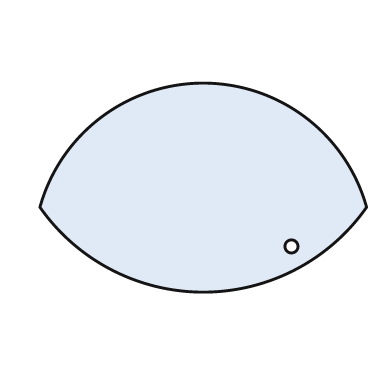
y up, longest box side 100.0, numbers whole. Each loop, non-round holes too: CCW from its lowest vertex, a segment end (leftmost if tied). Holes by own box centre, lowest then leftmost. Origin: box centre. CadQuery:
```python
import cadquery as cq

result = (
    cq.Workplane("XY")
    .moveTo(-50.0, -6.0)
    .threePointArc((0.0, -32.0), (50.0, -6.0))
    .threePointArc((0.0, 32.0), (-50.0, -6.0))
    .close()
    .moveTo(27.0, -18.0)
    .circle(2.0)
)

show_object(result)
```